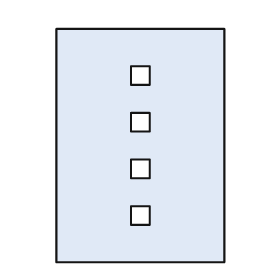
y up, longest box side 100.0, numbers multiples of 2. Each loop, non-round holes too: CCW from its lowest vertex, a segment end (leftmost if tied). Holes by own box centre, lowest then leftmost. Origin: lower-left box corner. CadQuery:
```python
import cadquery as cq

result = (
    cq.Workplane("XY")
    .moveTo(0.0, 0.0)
    .lineTo(72.0, 0.0)
    .lineTo(72.0, 100.0)
    .lineTo(0.0, 100.0)
    .close()
    .moveTo(32.0, 16.0)
    .lineTo(40.0, 16.0)
    .lineTo(40.0, 24.0)
    .lineTo(32.0, 24.0)
    .close()
    .moveTo(32.0, 36.0)
    .lineTo(40.0, 36.0)
    .lineTo(40.0, 44.0)
    .lineTo(32.0, 44.0)
    .close()
    .moveTo(32.0, 56.0)
    .lineTo(40.0, 56.0)
    .lineTo(40.0, 64.0)
    .lineTo(32.0, 64.0)
    .close()
    .moveTo(32.0, 76.0)
    .lineTo(40.0, 76.0)
    .lineTo(40.0, 84.0)
    .lineTo(32.0, 84.0)
    .close()
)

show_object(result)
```